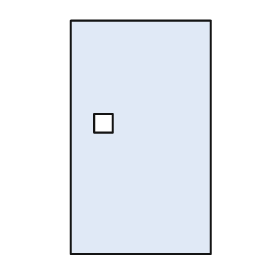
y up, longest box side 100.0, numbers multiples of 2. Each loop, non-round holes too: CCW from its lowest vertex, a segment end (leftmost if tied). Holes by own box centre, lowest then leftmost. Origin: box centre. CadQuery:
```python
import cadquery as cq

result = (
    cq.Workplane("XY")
    .moveTo(-30.0, -50.0)
    .lineTo(30.0, -50.0)
    .lineTo(30.0, 50.0)
    .lineTo(-30.0, 50.0)
    .close()
    .moveTo(-20.0, 2.0)
    .lineTo(-12.0, 2.0)
    .lineTo(-12.0, 10.0)
    .lineTo(-20.0, 10.0)
    .close()
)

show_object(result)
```